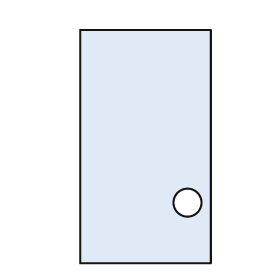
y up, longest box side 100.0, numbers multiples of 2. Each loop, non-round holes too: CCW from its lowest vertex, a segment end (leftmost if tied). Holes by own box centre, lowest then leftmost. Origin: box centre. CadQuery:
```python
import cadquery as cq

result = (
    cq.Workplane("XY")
    .moveTo(-28.0, -50.0)
    .lineTo(28.0, -50.0)
    .lineTo(28.0, 50.0)
    .lineTo(-28.0, 50.0)
    .close()
    .moveTo(18.0, -24.0)
    .circle(6.0)
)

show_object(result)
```